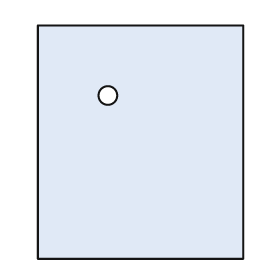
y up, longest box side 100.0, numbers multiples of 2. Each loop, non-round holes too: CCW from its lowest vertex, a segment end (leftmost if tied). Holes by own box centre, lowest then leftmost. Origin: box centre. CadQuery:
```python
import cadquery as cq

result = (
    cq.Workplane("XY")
    .moveTo(-44.0, -50.0)
    .lineTo(44.0, -50.0)
    .lineTo(44.0, 50.0)
    .lineTo(-44.0, 50.0)
    .close()
    .moveTo(-14.0, 20.0)
    .circle(4.0)
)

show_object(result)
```